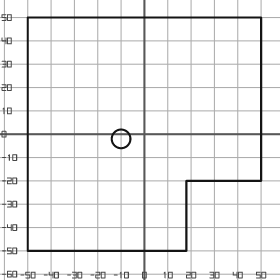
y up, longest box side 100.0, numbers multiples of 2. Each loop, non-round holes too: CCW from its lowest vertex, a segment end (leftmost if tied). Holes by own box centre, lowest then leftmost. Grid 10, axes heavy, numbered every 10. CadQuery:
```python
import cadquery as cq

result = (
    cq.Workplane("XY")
    .moveTo(-50.0, -50.0)
    .lineTo(18.0, -50.0)
    .lineTo(18.0, -20.0)
    .lineTo(50.0, -20.0)
    .lineTo(50.0, 50.0)
    .lineTo(-50.0, 50.0)
    .close()
    .moveTo(-10.0, -2.0)
    .circle(4.0)
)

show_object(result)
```